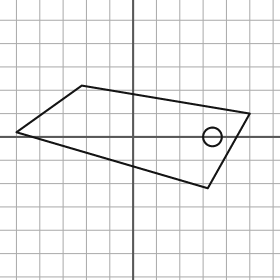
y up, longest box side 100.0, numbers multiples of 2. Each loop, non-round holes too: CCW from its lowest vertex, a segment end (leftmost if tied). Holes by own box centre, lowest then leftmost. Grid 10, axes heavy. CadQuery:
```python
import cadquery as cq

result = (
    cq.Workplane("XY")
    .moveTo(32.0, -22.0)
    .lineTo(50.0, 10.0)
    .lineTo(-22.0, 22.0)
    .lineTo(-50.0, 2.0)
    .close()
    .moveTo(34.0, 0.0)
    .circle(4.0)
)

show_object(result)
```